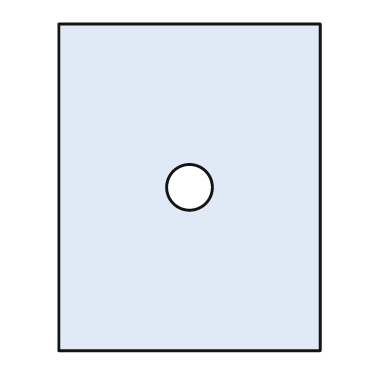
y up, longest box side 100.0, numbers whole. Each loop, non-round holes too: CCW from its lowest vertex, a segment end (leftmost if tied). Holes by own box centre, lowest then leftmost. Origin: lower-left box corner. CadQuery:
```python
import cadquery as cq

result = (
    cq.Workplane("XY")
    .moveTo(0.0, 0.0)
    .lineTo(80.0, 0.0)
    .lineTo(80.0, 100.0)
    .lineTo(0.0, 100.0)
    .close()
    .moveTo(40.0, 50.0)
    .circle(7.0)
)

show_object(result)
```